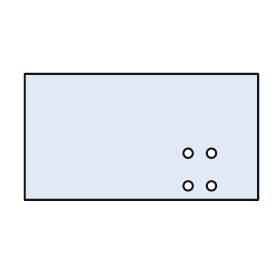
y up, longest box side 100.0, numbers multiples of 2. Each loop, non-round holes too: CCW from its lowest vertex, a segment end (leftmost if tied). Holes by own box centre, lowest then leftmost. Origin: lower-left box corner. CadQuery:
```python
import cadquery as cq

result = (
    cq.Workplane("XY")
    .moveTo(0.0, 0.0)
    .lineTo(100.0, 0.0)
    .lineTo(100.0, 54.0)
    .lineTo(0.0, 54.0)
    .close()
    .moveTo(70.0, 6.0)
    .circle(2.0)
    .moveTo(80.0, 6.0)
    .circle(2.0)
    .moveTo(70.0, 20.0)
    .circle(2.0)
    .moveTo(80.0, 20.0)
    .circle(2.0)
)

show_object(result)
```